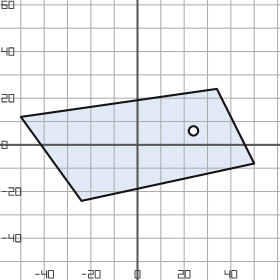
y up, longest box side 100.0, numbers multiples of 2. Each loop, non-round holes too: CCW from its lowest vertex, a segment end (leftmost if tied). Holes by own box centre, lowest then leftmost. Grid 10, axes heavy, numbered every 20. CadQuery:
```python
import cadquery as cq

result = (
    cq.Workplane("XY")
    .moveTo(-24.0, -24.0)
    .lineTo(50.0, -8.0)
    .lineTo(34.0, 24.0)
    .lineTo(-50.0, 12.0)
    .close()
    .moveTo(24.0, 6.0)
    .circle(2.0)
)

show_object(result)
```